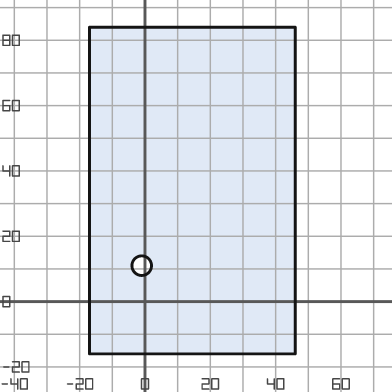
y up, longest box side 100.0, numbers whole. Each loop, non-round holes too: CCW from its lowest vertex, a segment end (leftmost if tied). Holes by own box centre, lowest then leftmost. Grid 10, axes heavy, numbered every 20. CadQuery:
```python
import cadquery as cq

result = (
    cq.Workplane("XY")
    .moveTo(-17.0, -16.0)
    .lineTo(46.0, -16.0)
    .lineTo(46.0, 84.0)
    .lineTo(-17.0, 84.0)
    .close()
    .moveTo(-1.0, 11.0)
    .circle(3.0)
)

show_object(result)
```